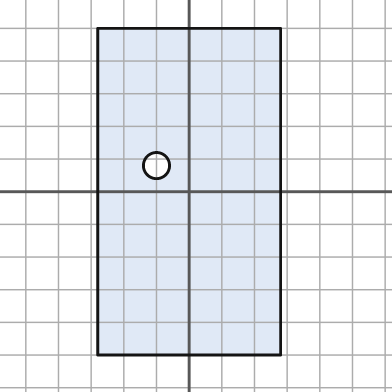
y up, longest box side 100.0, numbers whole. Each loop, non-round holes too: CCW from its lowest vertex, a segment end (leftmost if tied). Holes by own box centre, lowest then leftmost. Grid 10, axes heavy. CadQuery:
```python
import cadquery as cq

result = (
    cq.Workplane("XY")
    .moveTo(-28.0, -50.0)
    .lineTo(28.0, -50.0)
    .lineTo(28.0, 50.0)
    .lineTo(-28.0, 50.0)
    .close()
    .moveTo(-10.0, 8.0)
    .circle(4.0)
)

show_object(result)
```